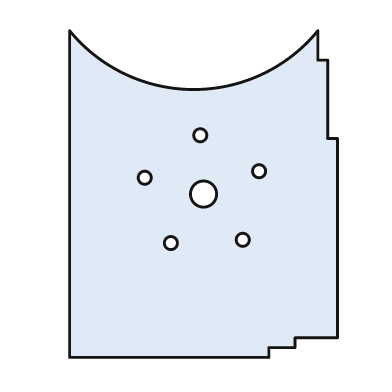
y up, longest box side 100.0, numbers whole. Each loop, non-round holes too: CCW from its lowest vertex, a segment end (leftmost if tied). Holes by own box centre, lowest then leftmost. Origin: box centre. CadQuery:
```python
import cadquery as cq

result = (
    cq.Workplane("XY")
    .moveTo(-41.0, -50.0)
    .lineTo(20.0, -50.0)
    .lineTo(20.0, -47.0)
    .lineTo(28.0, -47.0)
    .lineTo(28.0, -44.0)
    .lineTo(41.0, -44.0)
    .lineTo(41.0, 17.0)
    .lineTo(38.0, 17.0)
    .lineTo(38.0, 41.0)
    .lineTo(35.0, 41.0)
    .lineTo(35.0, 50.0)
    .threePointArc((-3.0, 32.0), (-41.0, 50.0))
    .close()
    .moveTo(-10.0, -15.0)
    .circle(2.0)
    .moveTo(12.0, -14.0)
    .circle(2.0)
    .moveTo(0.0, 0.0)
    .circle(4.0)
    .moveTo(-18.0, 5.0)
    .circle(2.0)
    .moveTo(17.0, 7.0)
    .circle(2.0)
    .moveTo(-1.0, 18.0)
    .circle(2.0)
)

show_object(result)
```